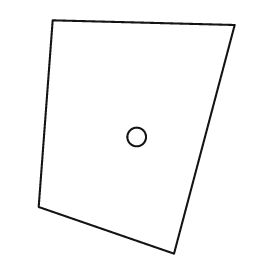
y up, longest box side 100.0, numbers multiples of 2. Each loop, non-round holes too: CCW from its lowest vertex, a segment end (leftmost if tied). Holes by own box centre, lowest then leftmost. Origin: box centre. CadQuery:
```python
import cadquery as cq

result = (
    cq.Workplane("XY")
    .moveTo(16.0, -50.0)
    .lineTo(42.0, 48.0)
    .lineTo(-36.0, 50.0)
    .lineTo(-42.0, -30.0)
    .close()
    .moveTo(0.0, 0.0)
    .circle(4.0)
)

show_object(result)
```